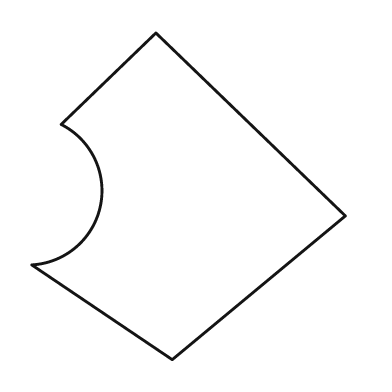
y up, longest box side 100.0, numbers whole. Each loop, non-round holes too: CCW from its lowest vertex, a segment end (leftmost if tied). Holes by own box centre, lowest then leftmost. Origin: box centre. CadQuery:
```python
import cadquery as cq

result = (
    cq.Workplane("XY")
    .moveTo(-5.0, -50.0)
    .lineTo(48.0, -6.0)
    .lineTo(-10.0, 50.0)
    .lineTo(-39.0, 22.0)
    .threePointArc((-27.0, -3.0), (-48.0, -21.0))
    .close()
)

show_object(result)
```